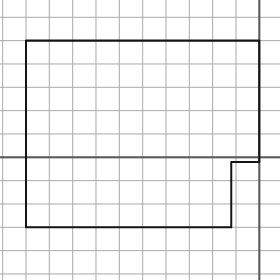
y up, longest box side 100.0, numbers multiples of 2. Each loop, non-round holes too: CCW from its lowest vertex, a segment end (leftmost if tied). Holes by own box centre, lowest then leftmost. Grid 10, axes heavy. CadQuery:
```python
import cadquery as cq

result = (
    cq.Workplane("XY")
    .moveTo(-100.0, -30.0)
    .lineTo(-12.0, -30.0)
    .lineTo(-12.0, -2.0)
    .lineTo(0.0, -2.0)
    .lineTo(0.0, 50.0)
    .lineTo(-100.0, 50.0)
    .close()
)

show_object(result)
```